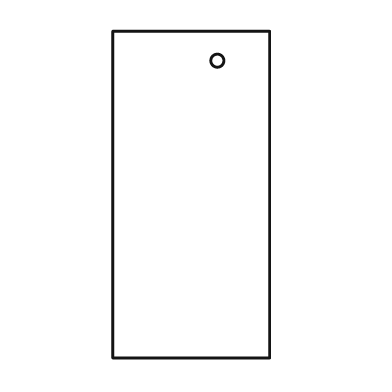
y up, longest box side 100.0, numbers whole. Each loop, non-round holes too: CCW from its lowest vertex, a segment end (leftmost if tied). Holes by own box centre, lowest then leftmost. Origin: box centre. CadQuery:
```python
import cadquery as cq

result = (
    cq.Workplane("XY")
    .moveTo(-24.0, -50.0)
    .lineTo(24.0, -50.0)
    .lineTo(24.0, 50.0)
    .lineTo(-24.0, 50.0)
    .close()
    .moveTo(8.0, 41.0)
    .circle(2.0)
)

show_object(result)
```